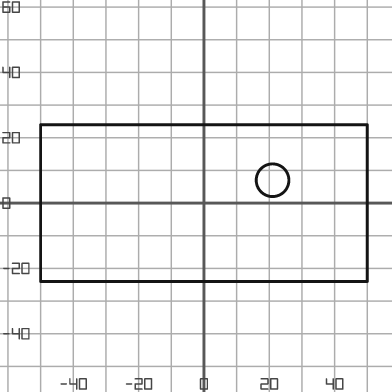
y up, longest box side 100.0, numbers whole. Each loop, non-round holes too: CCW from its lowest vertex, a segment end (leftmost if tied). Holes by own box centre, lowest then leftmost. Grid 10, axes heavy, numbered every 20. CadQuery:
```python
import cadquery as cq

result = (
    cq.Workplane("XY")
    .moveTo(-50.0, -24.0)
    .lineTo(50.0, -24.0)
    .lineTo(50.0, 24.0)
    .lineTo(-50.0, 24.0)
    .close()
    .moveTo(21.0, 7.0)
    .circle(5.0)
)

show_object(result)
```